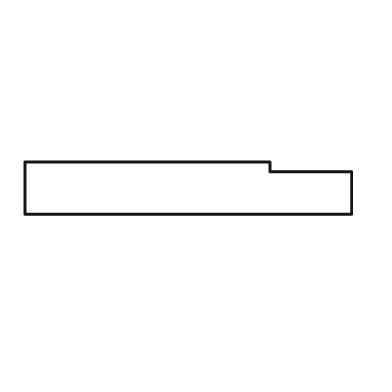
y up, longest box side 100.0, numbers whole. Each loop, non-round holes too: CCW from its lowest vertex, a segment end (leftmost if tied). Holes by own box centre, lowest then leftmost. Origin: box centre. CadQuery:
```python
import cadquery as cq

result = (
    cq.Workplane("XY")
    .moveTo(-50.0, -8.0)
    .lineTo(50.0, -8.0)
    .lineTo(50.0, 5.0)
    .lineTo(25.0, 5.0)
    .lineTo(25.0, 8.0)
    .lineTo(-50.0, 8.0)
    .close()
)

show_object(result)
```